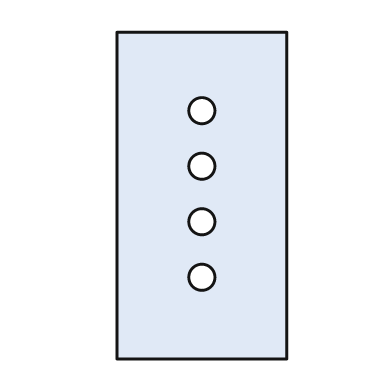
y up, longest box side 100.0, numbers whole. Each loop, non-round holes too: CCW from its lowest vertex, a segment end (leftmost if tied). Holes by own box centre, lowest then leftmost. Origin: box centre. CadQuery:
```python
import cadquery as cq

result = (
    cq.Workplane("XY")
    .moveTo(-26.0, -50.0)
    .lineTo(26.0, -50.0)
    .lineTo(26.0, 50.0)
    .lineTo(-26.0, 50.0)
    .close()
    .moveTo(0.0, -25.0)
    .circle(4.0)
    .moveTo(0.0, -8.0)
    .circle(4.0)
    .moveTo(0.0, 9.0)
    .circle(4.0)
    .moveTo(0.0, 26.0)
    .circle(4.0)
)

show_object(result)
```